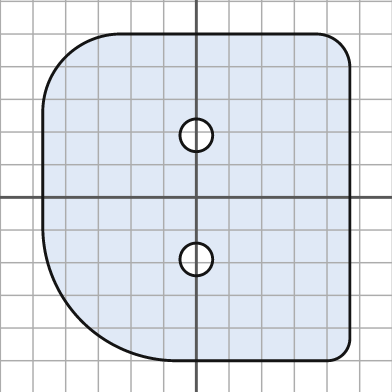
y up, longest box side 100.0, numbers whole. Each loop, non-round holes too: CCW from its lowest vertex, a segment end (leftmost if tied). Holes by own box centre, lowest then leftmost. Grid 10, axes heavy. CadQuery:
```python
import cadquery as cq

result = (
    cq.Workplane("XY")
    .moveTo(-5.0, -50.0)
    .lineTo(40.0, -50.0)
    .threePointArc((45.0, -48.0), (47.0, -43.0))
    .lineTo(47.0, 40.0)
    .threePointArc((44.0, 47.0), (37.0, 50.0))
    .lineTo(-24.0, 50.0)
    .threePointArc((-40.0, 43.0), (-47.0, 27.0))
    .lineTo(-47.0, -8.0)
    .threePointArc((-35.0, -38.0), (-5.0, -50.0))
    .close()
    .moveTo(0.0, -19.0)
    .circle(5.0)
    .moveTo(0.0, 19.0)
    .circle(5.0)
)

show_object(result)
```